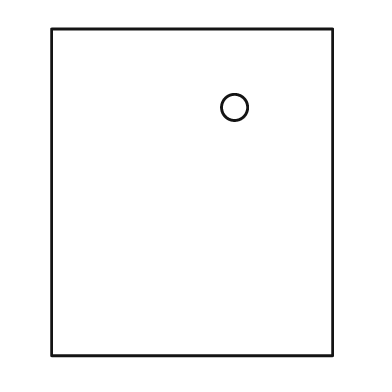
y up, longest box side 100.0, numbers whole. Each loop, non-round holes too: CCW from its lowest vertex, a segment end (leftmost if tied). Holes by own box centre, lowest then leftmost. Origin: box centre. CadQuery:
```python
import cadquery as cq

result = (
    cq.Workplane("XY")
    .moveTo(-43.0, -50.0)
    .lineTo(43.0, -50.0)
    .lineTo(43.0, 50.0)
    .lineTo(-43.0, 50.0)
    .close()
    .moveTo(13.0, 26.0)
    .circle(4.0)
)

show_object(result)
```